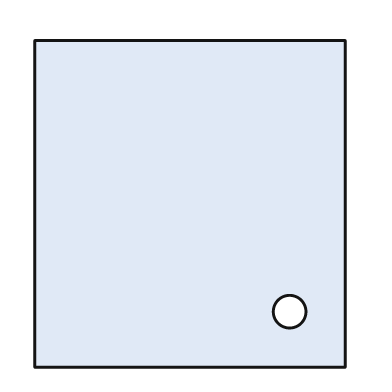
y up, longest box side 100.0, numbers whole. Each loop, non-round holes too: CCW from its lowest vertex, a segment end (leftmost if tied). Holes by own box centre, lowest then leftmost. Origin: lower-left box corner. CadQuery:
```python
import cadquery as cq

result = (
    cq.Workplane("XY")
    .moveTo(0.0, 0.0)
    .lineTo(95.0, 0.0)
    .lineTo(95.0, 100.0)
    .lineTo(0.0, 100.0)
    .close()
    .moveTo(78.0, 17.0)
    .circle(5.0)
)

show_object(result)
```